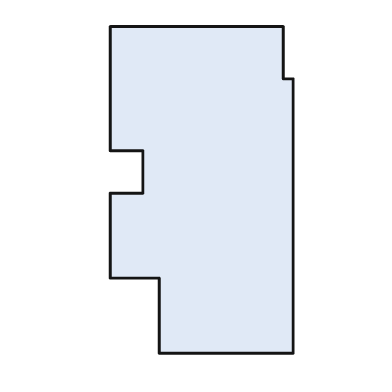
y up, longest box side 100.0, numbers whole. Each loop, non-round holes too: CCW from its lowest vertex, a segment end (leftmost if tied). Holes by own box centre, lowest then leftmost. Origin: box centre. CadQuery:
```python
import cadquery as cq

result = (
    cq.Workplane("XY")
    .moveTo(-13.0, -50.0)
    .lineTo(28.0, -50.0)
    .lineTo(28.0, 34.0)
    .lineTo(25.0, 34.0)
    .lineTo(25.0, 50.0)
    .lineTo(-28.0, 50.0)
    .lineTo(-28.0, 12.0)
    .lineTo(-18.0, 12.0)
    .lineTo(-18.0, -1.0)
    .lineTo(-28.0, -1.0)
    .lineTo(-28.0, -27.0)
    .lineTo(-13.0, -27.0)
    .close()
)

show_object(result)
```